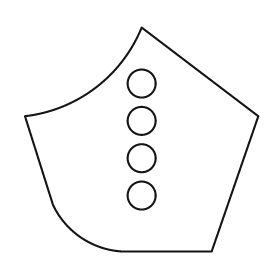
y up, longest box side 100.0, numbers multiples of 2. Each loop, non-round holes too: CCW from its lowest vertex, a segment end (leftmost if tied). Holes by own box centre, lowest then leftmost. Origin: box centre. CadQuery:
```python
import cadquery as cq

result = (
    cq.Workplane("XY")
    .moveTo(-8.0, -48.0)
    .lineTo(30.0, -48.0)
    .lineTo(50.0, 10.0)
    .lineTo(0.0, 48.0)
    .threePointArc((-20.0, 22.0), (-50.0, 10.0))
    .lineTo(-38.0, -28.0)
    .threePointArc((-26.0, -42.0), (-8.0, -48.0))
    .close()
    .moveTo(0.0, -24.0)
    .circle(6.0)
    .moveTo(0.0, -8.0)
    .circle(6.0)
    .moveTo(0.0, 8.0)
    .circle(6.0)
    .moveTo(0.0, 24.0)
    .circle(6.0)
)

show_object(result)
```